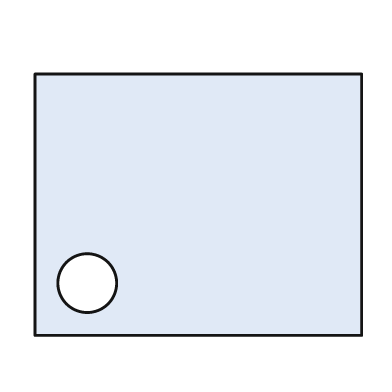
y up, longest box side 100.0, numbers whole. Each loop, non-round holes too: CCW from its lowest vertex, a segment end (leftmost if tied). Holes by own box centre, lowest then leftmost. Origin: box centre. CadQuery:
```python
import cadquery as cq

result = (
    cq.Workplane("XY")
    .moveTo(-50.0, -40.0)
    .lineTo(50.0, -40.0)
    .lineTo(50.0, 40.0)
    .lineTo(-50.0, 40.0)
    .close()
    .moveTo(-34.0, -24.0)
    .circle(9.0)
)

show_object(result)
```